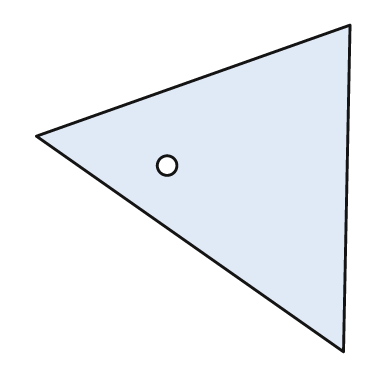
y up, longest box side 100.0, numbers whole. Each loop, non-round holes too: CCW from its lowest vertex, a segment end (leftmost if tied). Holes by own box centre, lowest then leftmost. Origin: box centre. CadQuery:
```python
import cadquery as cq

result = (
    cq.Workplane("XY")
    .moveTo(46.0, -50.0)
    .lineTo(48.0, 50.0)
    .lineTo(-48.0, 16.0)
    .close()
    .moveTo(-8.0, 7.0)
    .circle(3.0)
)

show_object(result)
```